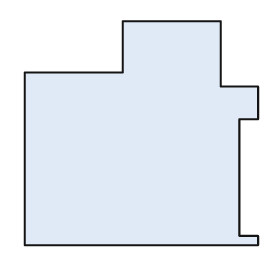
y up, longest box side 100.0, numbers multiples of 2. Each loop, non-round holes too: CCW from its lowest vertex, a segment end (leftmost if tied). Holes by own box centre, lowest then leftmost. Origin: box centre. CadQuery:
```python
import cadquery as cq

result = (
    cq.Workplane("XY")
    .moveTo(-50.0, -48.0)
    .lineTo(50.0, -48.0)
    .lineTo(50.0, -44.0)
    .lineTo(42.0, -44.0)
    .lineTo(42.0, 6.0)
    .lineTo(50.0, 6.0)
    .lineTo(50.0, 20.0)
    .lineTo(34.0, 20.0)
    .lineTo(34.0, 48.0)
    .lineTo(-8.0, 48.0)
    .lineTo(-8.0, 26.0)
    .lineTo(-50.0, 26.0)
    .close()
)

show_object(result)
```